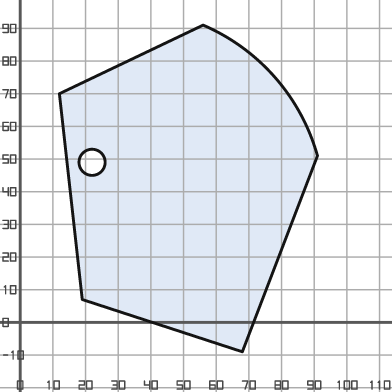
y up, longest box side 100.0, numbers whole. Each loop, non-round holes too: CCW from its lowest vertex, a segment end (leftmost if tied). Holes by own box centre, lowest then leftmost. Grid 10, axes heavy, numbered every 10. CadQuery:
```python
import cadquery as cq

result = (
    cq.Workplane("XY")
    .moveTo(68.0, -9.0)
    .lineTo(91.0, 51.0)
    .threePointArc((78.0, 75.0), (56.0, 91.0))
    .lineTo(12.0, 70.0)
    .lineTo(19.0, 7.0)
    .close()
    .moveTo(22.0, 49.0)
    .circle(4.0)
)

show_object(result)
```